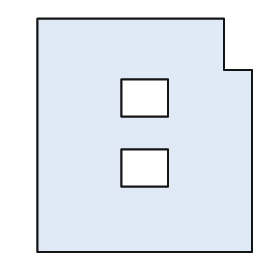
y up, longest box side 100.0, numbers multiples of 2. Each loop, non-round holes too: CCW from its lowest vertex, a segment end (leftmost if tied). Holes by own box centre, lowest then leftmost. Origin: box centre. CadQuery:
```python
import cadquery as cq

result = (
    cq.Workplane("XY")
    .moveTo(-46.0, -50.0)
    .lineTo(46.0, -50.0)
    .lineTo(46.0, 28.0)
    .lineTo(34.0, 28.0)
    .lineTo(34.0, 50.0)
    .lineTo(-46.0, 50.0)
    .close()
    .moveTo(-10.0, -22.0)
    .lineTo(10.0, -22.0)
    .lineTo(10.0, -6.0)
    .lineTo(-10.0, -6.0)
    .close()
    .moveTo(-10.0, 8.0)
    .lineTo(10.0, 8.0)
    .lineTo(10.0, 24.0)
    .lineTo(-10.0, 24.0)
    .close()
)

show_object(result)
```